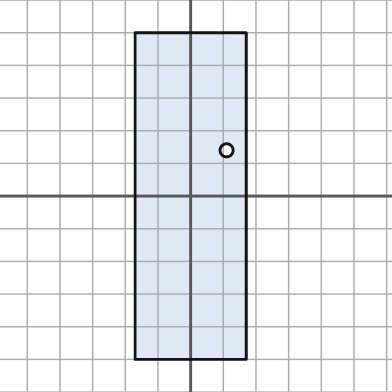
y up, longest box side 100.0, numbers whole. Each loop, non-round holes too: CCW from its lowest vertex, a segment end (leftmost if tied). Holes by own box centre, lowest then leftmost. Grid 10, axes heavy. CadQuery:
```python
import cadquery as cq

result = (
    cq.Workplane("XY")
    .moveTo(-17.0, -50.0)
    .lineTo(17.0, -50.0)
    .lineTo(17.0, 50.0)
    .lineTo(-17.0, 50.0)
    .close()
    .moveTo(11.0, 14.0)
    .circle(2.0)
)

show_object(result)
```